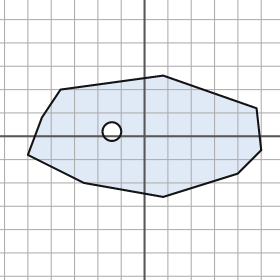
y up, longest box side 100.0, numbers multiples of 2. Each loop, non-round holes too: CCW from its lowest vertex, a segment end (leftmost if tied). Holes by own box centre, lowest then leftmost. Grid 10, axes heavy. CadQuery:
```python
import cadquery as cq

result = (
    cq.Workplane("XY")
    .moveTo(8.0, -26.0)
    .lineTo(40.0, -16.0)
    .lineTo(50.0, -6.0)
    .lineTo(48.0, 12.0)
    .lineTo(8.0, 26.0)
    .lineTo(-36.0, 20.0)
    .lineTo(-44.0, 8.0)
    .lineTo(-50.0, -8.0)
    .lineTo(-26.0, -20.0)
    .close()
    .moveTo(-14.0, 2.0)
    .circle(4.0)
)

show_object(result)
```